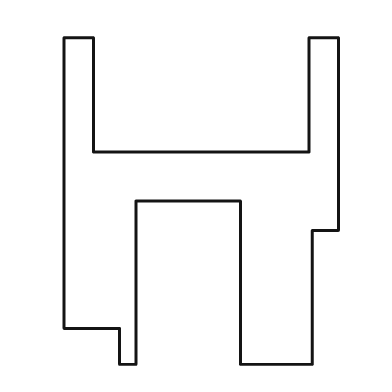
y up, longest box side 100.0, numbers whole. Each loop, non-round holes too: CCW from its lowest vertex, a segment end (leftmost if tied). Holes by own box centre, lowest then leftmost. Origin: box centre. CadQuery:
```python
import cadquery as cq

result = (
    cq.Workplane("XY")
    .moveTo(-25.0, -50.0)
    .lineTo(-20.0, -50.0)
    .lineTo(-20.0, 0.0)
    .lineTo(12.0, 0.0)
    .lineTo(12.0, -50.0)
    .lineTo(34.0, -50.0)
    .lineTo(34.0, -9.0)
    .lineTo(42.0, -9.0)
    .lineTo(42.0, 50.0)
    .lineTo(33.0, 50.0)
    .lineTo(33.0, 15.0)
    .lineTo(-33.0, 15.0)
    .lineTo(-33.0, 50.0)
    .lineTo(-42.0, 50.0)
    .lineTo(-42.0, -39.0)
    .lineTo(-25.0, -39.0)
    .close()
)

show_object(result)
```